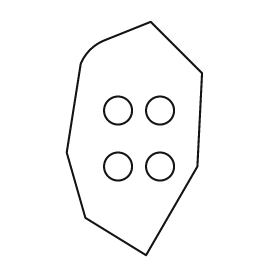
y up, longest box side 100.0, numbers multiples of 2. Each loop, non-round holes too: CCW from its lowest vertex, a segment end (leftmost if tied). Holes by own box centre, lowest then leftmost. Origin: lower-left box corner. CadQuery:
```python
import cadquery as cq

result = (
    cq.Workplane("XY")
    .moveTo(34.0, 0.0)
    .lineTo(56.0, 38.0)
    .lineTo(58.0, 78.0)
    .lineTo(36.0, 100.0)
    .lineTo(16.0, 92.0)
    .threePointArc((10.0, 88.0), (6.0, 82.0))
    .lineTo(0.0, 44.0)
    .lineTo(8.0, 16.0)
    .close()
    .moveTo(22.0, 38.0)
    .circle(6.0)
    .moveTo(40.0, 38.0)
    .circle(6.0)
    .moveTo(22.0, 62.0)
    .circle(6.0)
    .moveTo(40.0, 62.0)
    .circle(6.0)
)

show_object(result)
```